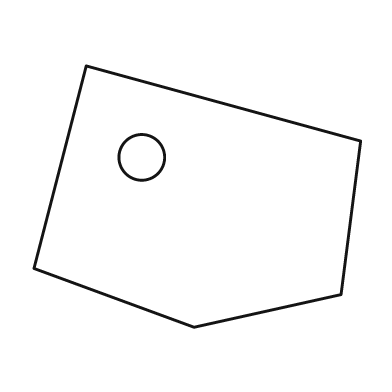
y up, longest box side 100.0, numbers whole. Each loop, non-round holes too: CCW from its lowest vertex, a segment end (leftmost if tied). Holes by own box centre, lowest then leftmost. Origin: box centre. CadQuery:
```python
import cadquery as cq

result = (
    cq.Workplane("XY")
    .moveTo(-1.0, -40.0)
    .lineTo(44.0, -30.0)
    .lineTo(50.0, 17.0)
    .lineTo(-34.0, 40.0)
    .lineTo(-50.0, -22.0)
    .close()
    .moveTo(-17.0, 12.0)
    .circle(7.0)
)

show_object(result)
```